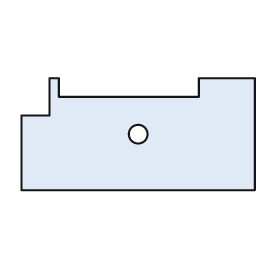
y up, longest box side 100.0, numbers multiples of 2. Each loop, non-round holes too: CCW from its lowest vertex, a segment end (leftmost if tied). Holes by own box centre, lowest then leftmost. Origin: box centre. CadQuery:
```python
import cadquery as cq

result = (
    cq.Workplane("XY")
    .moveTo(-50.0, -24.0)
    .lineTo(50.0, -24.0)
    .lineTo(50.0, 24.0)
    .lineTo(26.0, 24.0)
    .lineTo(26.0, 16.0)
    .lineTo(-34.0, 16.0)
    .lineTo(-34.0, 24.0)
    .lineTo(-38.0, 24.0)
    .lineTo(-38.0, 8.0)
    .lineTo(-50.0, 8.0)
    .close()
    .moveTo(0.0, 0.0)
    .circle(4.0)
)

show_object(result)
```